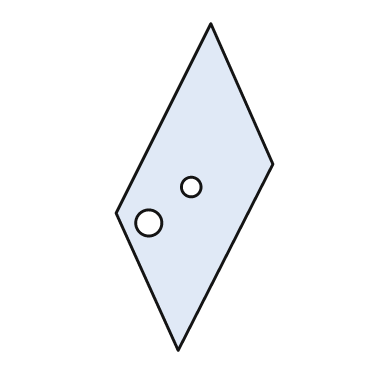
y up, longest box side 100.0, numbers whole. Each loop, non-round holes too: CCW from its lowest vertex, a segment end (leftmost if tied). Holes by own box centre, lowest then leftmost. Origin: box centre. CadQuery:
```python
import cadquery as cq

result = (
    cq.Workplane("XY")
    .moveTo(-5.0, -50.0)
    .lineTo(24.0, 7.0)
    .lineTo(5.0, 50.0)
    .lineTo(-24.0, -8.0)
    .close()
    .moveTo(-14.0, -11.0)
    .circle(4.0)
    .moveTo(-1.0, 0.0)
    .circle(3.0)
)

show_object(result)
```